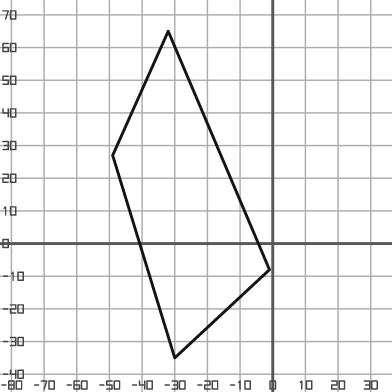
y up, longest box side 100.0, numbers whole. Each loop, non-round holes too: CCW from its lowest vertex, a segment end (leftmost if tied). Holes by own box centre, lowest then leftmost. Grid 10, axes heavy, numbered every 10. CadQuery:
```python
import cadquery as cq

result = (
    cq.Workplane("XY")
    .moveTo(-30.0, -35.0)
    .lineTo(-1.0, -8.0)
    .lineTo(-32.0, 65.0)
    .lineTo(-49.0, 27.0)
    .close()
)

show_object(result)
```